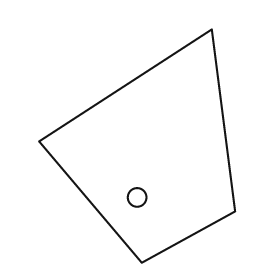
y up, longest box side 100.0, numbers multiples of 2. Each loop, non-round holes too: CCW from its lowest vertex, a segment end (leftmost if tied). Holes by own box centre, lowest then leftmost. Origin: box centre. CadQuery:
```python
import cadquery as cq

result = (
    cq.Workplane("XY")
    .moveTo(2.0, -50.0)
    .lineTo(42.0, -28.0)
    .lineTo(32.0, 50.0)
    .lineTo(-42.0, 2.0)
    .close()
    .moveTo(0.0, -22.0)
    .circle(4.0)
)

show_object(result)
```